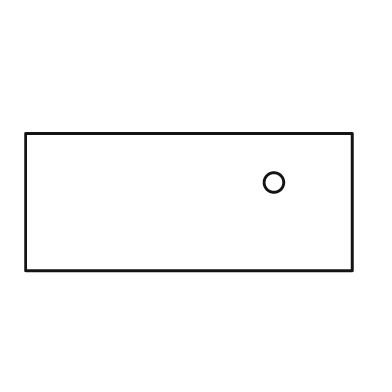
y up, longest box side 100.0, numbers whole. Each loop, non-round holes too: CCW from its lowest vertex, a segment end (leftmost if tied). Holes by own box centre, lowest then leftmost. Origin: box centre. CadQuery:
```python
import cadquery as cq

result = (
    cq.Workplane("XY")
    .moveTo(-50.0, -21.0)
    .lineTo(50.0, -21.0)
    .lineTo(50.0, 21.0)
    .lineTo(-50.0, 21.0)
    .close()
    .moveTo(26.0, 6.0)
    .circle(3.0)
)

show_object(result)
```